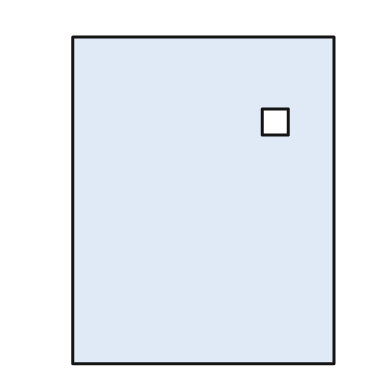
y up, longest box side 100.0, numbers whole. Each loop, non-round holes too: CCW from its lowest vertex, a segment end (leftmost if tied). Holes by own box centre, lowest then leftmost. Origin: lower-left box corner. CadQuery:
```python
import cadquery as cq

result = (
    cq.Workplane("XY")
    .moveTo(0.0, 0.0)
    .lineTo(80.0, 0.0)
    .lineTo(80.0, 100.0)
    .lineTo(0.0, 100.0)
    .close()
    .moveTo(58.0, 70.0)
    .lineTo(66.0, 70.0)
    .lineTo(66.0, 78.0)
    .lineTo(58.0, 78.0)
    .close()
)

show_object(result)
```